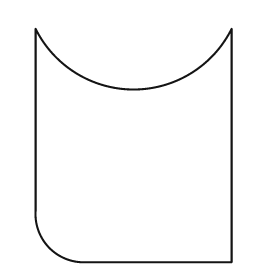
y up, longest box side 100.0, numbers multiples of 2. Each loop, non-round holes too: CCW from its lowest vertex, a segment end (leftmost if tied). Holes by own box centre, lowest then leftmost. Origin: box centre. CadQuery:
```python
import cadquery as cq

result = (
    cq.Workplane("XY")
    .moveTo(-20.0, -50.0)
    .lineTo(42.0, -50.0)
    .lineTo(42.0, 50.0)
    .threePointArc((0.0, 24.0), (-42.0, 50.0))
    .lineTo(-42.0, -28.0)
    .threePointArc((-36.0, -44.0), (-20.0, -50.0))
    .close()
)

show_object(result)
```